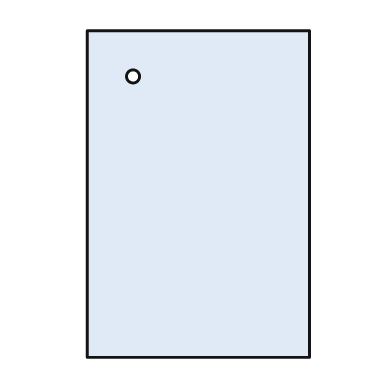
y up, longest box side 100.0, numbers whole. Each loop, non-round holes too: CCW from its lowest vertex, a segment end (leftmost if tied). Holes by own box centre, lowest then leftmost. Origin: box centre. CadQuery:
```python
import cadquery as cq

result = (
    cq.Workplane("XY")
    .moveTo(-34.0, -50.0)
    .lineTo(34.0, -50.0)
    .lineTo(34.0, 50.0)
    .lineTo(-34.0, 50.0)
    .close()
    .moveTo(-20.0, 36.0)
    .circle(2.0)
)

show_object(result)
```